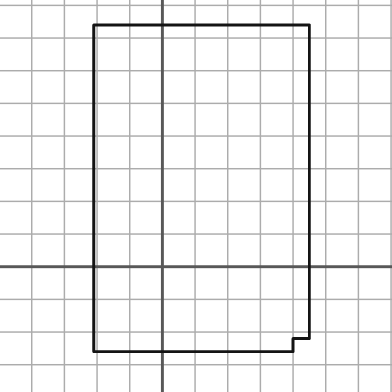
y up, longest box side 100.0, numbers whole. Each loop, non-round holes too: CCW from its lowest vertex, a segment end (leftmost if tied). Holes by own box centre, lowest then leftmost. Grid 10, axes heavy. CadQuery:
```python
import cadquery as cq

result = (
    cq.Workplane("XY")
    .moveTo(-21.0, -26.0)
    .lineTo(40.0, -26.0)
    .lineTo(40.0, -22.0)
    .lineTo(45.0, -22.0)
    .lineTo(45.0, 74.0)
    .lineTo(-21.0, 74.0)
    .close()
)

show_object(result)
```